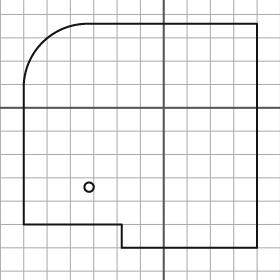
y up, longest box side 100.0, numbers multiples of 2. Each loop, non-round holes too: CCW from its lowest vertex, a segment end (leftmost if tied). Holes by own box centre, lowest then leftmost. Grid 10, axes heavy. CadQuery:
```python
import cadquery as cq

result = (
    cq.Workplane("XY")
    .moveTo(-18.0, -60.0)
    .lineTo(40.0, -60.0)
    .lineTo(40.0, 36.0)
    .lineTo(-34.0, 36.0)
    .threePointArc((-52.0, 28.0), (-60.0, 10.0))
    .lineTo(-60.0, -50.0)
    .lineTo(-18.0, -50.0)
    .close()
    .moveTo(-32.0, -34.0)
    .circle(2.0)
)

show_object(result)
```